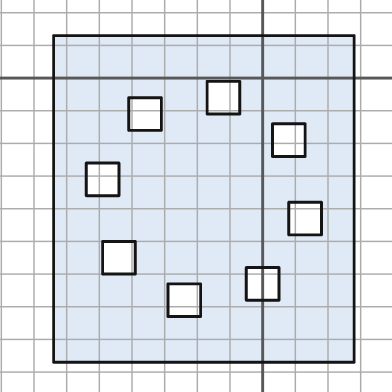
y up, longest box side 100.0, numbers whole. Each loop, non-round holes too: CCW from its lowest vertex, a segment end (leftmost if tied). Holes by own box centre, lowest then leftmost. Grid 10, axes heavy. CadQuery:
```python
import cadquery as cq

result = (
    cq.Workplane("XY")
    .moveTo(-64.0, -87.0)
    .lineTo(28.0, -87.0)
    .lineTo(28.0, 13.0)
    .lineTo(-64.0, 13.0)
    .close()
    .moveTo(-29.0, -73.0)
    .lineTo(-19.0, -73.0)
    .lineTo(-19.0, -63.0)
    .lineTo(-29.0, -63.0)
    .close()
    .moveTo(-5.0, -68.0)
    .lineTo(5.0, -68.0)
    .lineTo(5.0, -58.0)
    .lineTo(-5.0, -58.0)
    .close()
    .moveTo(-49.0, -60.0)
    .lineTo(-39.0, -60.0)
    .lineTo(-39.0, -50.0)
    .lineTo(-49.0, -50.0)
    .close()
    .moveTo(8.0, -48.0)
    .lineTo(18.0, -48.0)
    .lineTo(18.0, -38.0)
    .lineTo(8.0, -38.0)
    .close()
    .moveTo(-54.0, -36.0)
    .lineTo(-44.0, -36.0)
    .lineTo(-44.0, -26.0)
    .lineTo(-54.0, -26.0)
    .close()
    .moveTo(3.0, -24.0)
    .lineTo(13.0, -24.0)
    .lineTo(13.0, -14.0)
    .lineTo(3.0, -14.0)
    .close()
    .moveTo(-41.0, -16.0)
    .lineTo(-31.0, -16.0)
    .lineTo(-31.0, -6.0)
    .lineTo(-41.0, -6.0)
    .close()
    .moveTo(-17.0, -11.0)
    .lineTo(-7.0, -11.0)
    .lineTo(-7.0, -1.0)
    .lineTo(-17.0, -1.0)
    .close()
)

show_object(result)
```